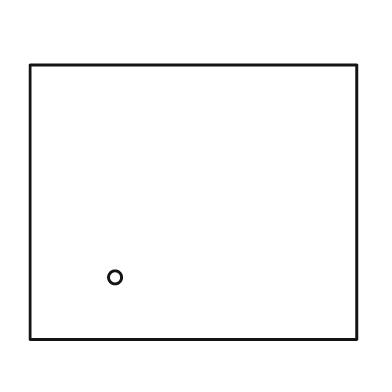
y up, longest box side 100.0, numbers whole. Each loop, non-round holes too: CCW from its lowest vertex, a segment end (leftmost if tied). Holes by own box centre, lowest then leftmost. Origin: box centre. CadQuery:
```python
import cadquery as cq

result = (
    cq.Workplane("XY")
    .moveTo(-50.0, -42.0)
    .lineTo(50.0, -42.0)
    .lineTo(50.0, 42.0)
    .lineTo(-50.0, 42.0)
    .close()
    .moveTo(-24.0, -23.0)
    .circle(2.0)
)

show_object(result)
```